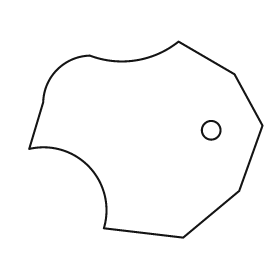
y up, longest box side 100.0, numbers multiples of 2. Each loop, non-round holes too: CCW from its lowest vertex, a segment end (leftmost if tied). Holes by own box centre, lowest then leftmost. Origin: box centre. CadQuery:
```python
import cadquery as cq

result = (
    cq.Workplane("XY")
    .moveTo(16.0, -42.0)
    .lineTo(40.0, -22.0)
    .lineTo(50.0, 6.0)
    .lineTo(38.0, 28.0)
    .lineTo(14.0, 42.0)
    .threePointArc((-4.0, 34.0), (-24.0, 36.0))
    .threePointArc((-38.0, 30.0), (-44.0, 16.0))
    .lineTo(-50.0, -4.0)
    .threePointArc((-24.0, -12.0), (-18.0, -38.0))
    .close()
    .moveTo(28.0, 4.0)
    .circle(4.0)
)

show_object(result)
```